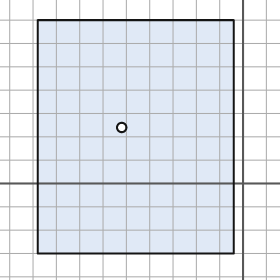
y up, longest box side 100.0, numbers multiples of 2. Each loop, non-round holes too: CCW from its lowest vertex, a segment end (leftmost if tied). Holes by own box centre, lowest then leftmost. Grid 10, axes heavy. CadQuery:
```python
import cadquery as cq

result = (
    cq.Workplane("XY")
    .moveTo(-88.0, -30.0)
    .lineTo(-4.0, -30.0)
    .lineTo(-4.0, 70.0)
    .lineTo(-88.0, 70.0)
    .close()
    .moveTo(-52.0, 24.0)
    .circle(2.0)
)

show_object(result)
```